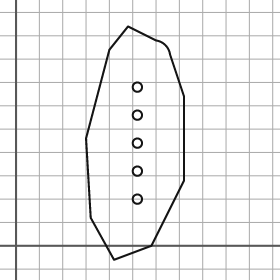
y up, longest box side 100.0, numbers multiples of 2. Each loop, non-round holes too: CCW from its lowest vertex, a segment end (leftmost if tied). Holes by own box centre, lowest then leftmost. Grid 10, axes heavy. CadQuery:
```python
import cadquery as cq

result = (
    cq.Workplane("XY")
    .moveTo(42.0, -6.0)
    .lineTo(58.0, 0.0)
    .lineTo(72.0, 28.0)
    .lineTo(72.0, 64.0)
    .lineTo(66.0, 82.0)
    .threePointArc((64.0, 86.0), (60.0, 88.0))
    .lineTo(48.0, 94.0)
    .lineTo(40.0, 84.0)
    .lineTo(30.0, 46.0)
    .lineTo(32.0, 12.0)
    .close()
    .moveTo(52.0, 20.0)
    .circle(2.0)
    .moveTo(52.0, 32.0)
    .circle(2.0)
    .moveTo(52.0, 44.0)
    .circle(2.0)
    .moveTo(52.0, 56.0)
    .circle(2.0)
    .moveTo(52.0, 68.0)
    .circle(2.0)
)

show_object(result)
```